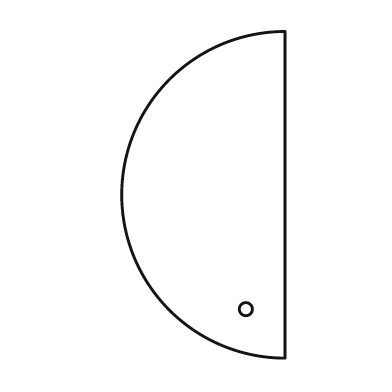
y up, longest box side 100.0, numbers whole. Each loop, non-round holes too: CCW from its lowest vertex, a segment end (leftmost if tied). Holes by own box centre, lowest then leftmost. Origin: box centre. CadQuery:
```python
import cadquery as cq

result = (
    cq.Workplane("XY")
    .moveTo(25.0, -50.0)
    .lineTo(25.0, 50.0)
    .threePointArc((-25.0, 0.0), (25.0, -50.0))
    .close()
    .moveTo(13.0, -35.0)
    .circle(2.0)
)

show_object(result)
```